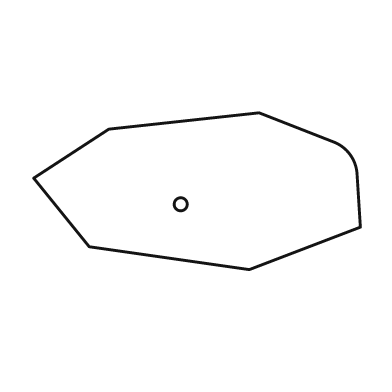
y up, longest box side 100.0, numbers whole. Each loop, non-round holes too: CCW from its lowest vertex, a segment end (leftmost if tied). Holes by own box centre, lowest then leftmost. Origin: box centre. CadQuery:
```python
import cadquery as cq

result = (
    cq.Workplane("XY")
    .moveTo(16.0, -24.0)
    .lineTo(50.0, -11.0)
    .lineTo(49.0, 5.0)
    .threePointArc((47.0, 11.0), (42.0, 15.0))
    .lineTo(19.0, 24.0)
    .lineTo(-27.0, 19.0)
    .lineTo(-50.0, 4.0)
    .lineTo(-33.0, -17.0)
    .close()
    .moveTo(-5.0, -4.0)
    .circle(2.0)
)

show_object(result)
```